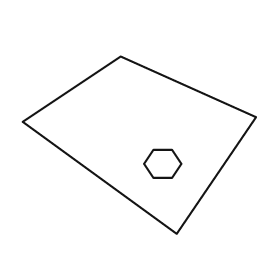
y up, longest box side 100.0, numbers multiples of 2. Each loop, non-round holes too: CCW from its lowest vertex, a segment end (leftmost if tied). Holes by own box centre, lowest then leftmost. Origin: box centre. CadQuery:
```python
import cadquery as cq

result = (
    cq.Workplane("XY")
    .moveTo(16.0, -38.0)
    .lineTo(50.0, 12.0)
    .lineTo(-8.0, 38.0)
    .lineTo(-50.0, 10.0)
    .close()
    .moveTo(6.0, -14.0)
    .lineTo(14.0, -14.0)
    .lineTo(18.0, -8.0)
    .lineTo(14.0, -2.0)
    .lineTo(6.0, -2.0)
    .lineTo(2.0, -8.0)
    .close()
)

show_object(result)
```